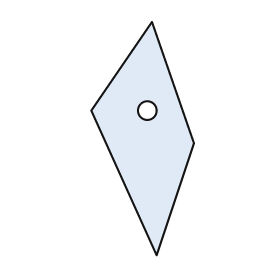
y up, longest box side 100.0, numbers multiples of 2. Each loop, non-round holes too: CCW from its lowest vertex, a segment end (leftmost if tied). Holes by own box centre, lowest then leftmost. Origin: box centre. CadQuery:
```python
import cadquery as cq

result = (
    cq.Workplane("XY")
    .moveTo(6.0, -50.0)
    .lineTo(22.0, -2.0)
    .lineTo(4.0, 50.0)
    .lineTo(-22.0, 12.0)
    .close()
    .moveTo(2.0, 12.0)
    .circle(4.0)
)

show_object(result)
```